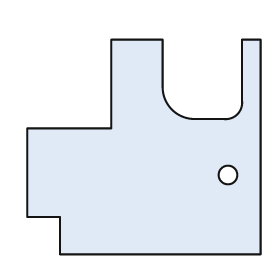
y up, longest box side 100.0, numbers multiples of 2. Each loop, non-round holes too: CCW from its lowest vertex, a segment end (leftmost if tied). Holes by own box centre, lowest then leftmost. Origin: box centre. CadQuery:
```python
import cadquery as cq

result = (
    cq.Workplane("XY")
    .moveTo(-36.0, -46.0)
    .lineTo(50.0, -46.0)
    .lineTo(50.0, 46.0)
    .lineTo(42.0, 46.0)
    .lineTo(42.0, 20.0)
    .threePointArc((40.0, 14.0), (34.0, 12.0))
    .lineTo(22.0, 12.0)
    .threePointArc((12.0, 16.0), (8.0, 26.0))
    .lineTo(8.0, 46.0)
    .lineTo(-14.0, 46.0)
    .lineTo(-14.0, 8.0)
    .lineTo(-50.0, 8.0)
    .lineTo(-50.0, -30.0)
    .lineTo(-36.0, -30.0)
    .close()
    .moveTo(36.0, -12.0)
    .circle(4.0)
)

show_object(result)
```